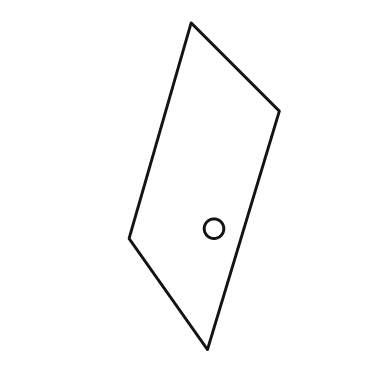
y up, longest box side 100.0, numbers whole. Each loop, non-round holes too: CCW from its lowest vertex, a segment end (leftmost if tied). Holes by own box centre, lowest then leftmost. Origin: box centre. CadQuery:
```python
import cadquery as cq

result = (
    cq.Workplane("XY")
    .moveTo(1.0, -50.0)
    .lineTo(23.0, 23.0)
    .lineTo(-4.0, 50.0)
    .lineTo(-23.0, -16.0)
    .close()
    .moveTo(3.0, -13.0)
    .circle(3.0)
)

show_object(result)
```